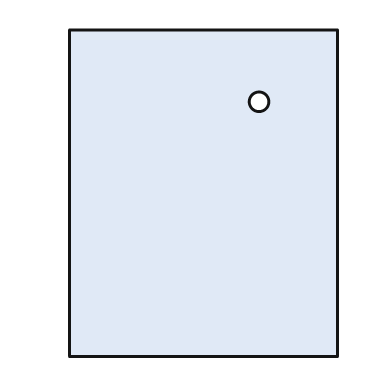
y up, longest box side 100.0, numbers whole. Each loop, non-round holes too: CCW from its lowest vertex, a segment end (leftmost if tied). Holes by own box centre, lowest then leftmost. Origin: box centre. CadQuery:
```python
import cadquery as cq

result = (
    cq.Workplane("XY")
    .moveTo(-41.0, -50.0)
    .lineTo(41.0, -50.0)
    .lineTo(41.0, 50.0)
    .lineTo(-41.0, 50.0)
    .close()
    .moveTo(17.0, 28.0)
    .circle(3.0)
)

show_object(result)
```